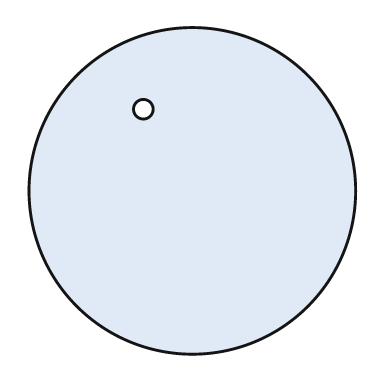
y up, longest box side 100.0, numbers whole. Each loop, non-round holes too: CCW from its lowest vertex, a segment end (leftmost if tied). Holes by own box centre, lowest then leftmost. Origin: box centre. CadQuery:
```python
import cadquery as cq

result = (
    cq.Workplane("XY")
    .moveTo(0.0, 0.0)
    .circle(50.0)
    .moveTo(-15.0, 25.0)
    .circle(3.0)
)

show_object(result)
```